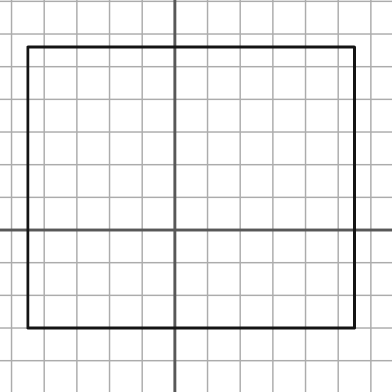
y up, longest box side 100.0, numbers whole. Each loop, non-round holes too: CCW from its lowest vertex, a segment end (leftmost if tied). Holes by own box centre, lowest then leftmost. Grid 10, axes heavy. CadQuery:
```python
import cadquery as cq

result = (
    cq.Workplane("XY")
    .moveTo(-45.0, -30.0)
    .lineTo(55.0, -30.0)
    .lineTo(55.0, 56.0)
    .lineTo(-45.0, 56.0)
    .close()
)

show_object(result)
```